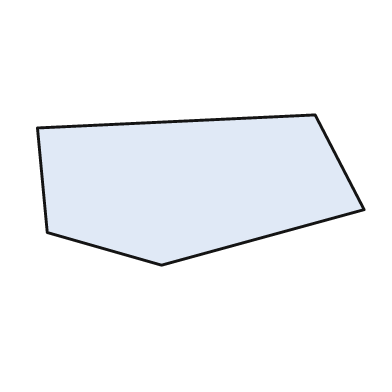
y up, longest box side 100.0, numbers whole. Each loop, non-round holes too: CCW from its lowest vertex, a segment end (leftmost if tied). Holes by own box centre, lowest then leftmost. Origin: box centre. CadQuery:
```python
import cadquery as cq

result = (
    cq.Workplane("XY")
    .moveTo(-12.0, -23.0)
    .lineTo(50.0, -6.0)
    .lineTo(35.0, 23.0)
    .lineTo(-50.0, 19.0)
    .lineTo(-47.0, -13.0)
    .close()
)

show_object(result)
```